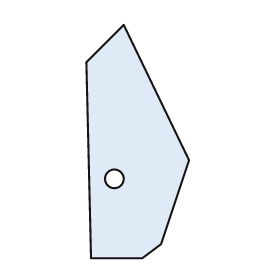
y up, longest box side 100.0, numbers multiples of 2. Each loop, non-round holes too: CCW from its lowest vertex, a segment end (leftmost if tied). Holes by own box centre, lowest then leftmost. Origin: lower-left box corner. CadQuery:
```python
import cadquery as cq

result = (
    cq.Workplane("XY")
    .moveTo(2.0, 0.0)
    .lineTo(24.0, 0.0)
    .lineTo(32.0, 6.0)
    .lineTo(44.0, 42.0)
    .lineTo(16.0, 100.0)
    .lineTo(0.0, 84.0)
    .close()
    .moveTo(12.0, 34.0)
    .circle(4.0)
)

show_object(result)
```